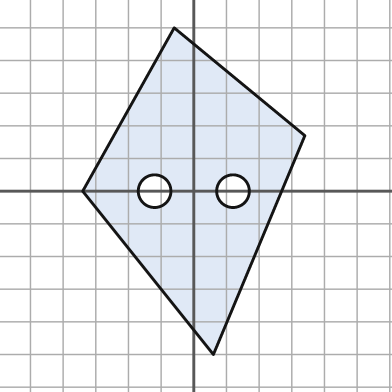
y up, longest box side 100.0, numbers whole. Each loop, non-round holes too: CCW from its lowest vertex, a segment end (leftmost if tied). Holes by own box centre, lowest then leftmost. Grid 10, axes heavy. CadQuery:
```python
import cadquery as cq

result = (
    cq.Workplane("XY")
    .moveTo(6.0, -50.0)
    .lineTo(34.0, 17.0)
    .lineTo(-6.0, 50.0)
    .lineTo(-34.0, 0.0)
    .close()
    .moveTo(-12.0, 0.0)
    .circle(5.0)
    .moveTo(12.0, 0.0)
    .circle(5.0)
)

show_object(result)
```